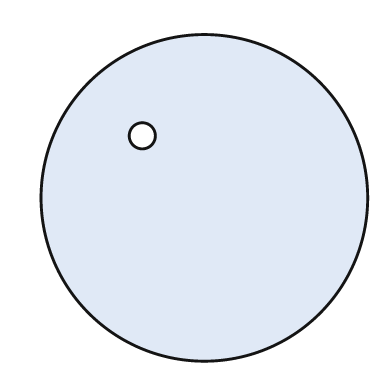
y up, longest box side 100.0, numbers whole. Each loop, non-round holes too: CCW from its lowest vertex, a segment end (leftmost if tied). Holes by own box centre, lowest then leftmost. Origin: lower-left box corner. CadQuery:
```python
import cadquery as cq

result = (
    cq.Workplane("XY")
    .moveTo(50.0, 50.0)
    .circle(50.0)
    .moveTo(31.0, 69.0)
    .circle(4.0)
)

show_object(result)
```